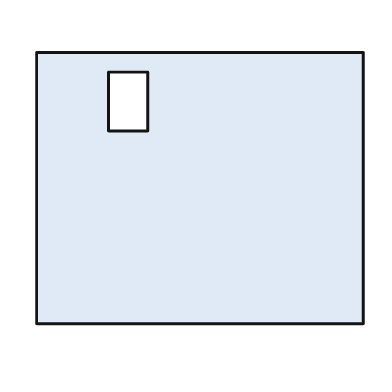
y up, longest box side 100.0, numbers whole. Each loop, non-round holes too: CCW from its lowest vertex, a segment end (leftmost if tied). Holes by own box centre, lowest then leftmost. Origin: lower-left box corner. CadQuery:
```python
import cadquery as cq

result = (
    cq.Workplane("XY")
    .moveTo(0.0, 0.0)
    .lineTo(100.0, 0.0)
    .lineTo(100.0, 83.0)
    .lineTo(0.0, 83.0)
    .close()
    .moveTo(22.0, 59.0)
    .lineTo(34.0, 59.0)
    .lineTo(34.0, 77.0)
    .lineTo(22.0, 77.0)
    .close()
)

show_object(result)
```